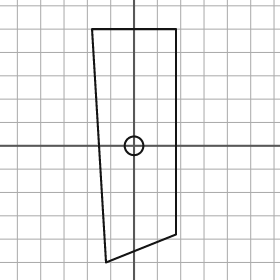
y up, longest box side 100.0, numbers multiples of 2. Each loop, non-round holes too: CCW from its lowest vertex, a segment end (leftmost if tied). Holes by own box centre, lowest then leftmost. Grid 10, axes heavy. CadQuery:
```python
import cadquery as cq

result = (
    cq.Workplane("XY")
    .moveTo(-12.0, -50.0)
    .lineTo(18.0, -38.0)
    .lineTo(18.0, 50.0)
    .lineTo(-18.0, 50.0)
    .close()
    .moveTo(0.0, 0.0)
    .circle(4.0)
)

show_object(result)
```